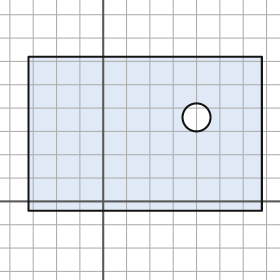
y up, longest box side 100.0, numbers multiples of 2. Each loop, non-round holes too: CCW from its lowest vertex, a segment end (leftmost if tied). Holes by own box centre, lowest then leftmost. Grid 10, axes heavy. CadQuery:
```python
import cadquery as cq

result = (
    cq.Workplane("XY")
    .moveTo(-32.0, -4.0)
    .lineTo(68.0, -4.0)
    .lineTo(68.0, 62.0)
    .lineTo(-32.0, 62.0)
    .close()
    .moveTo(40.0, 36.0)
    .circle(6.0)
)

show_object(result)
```